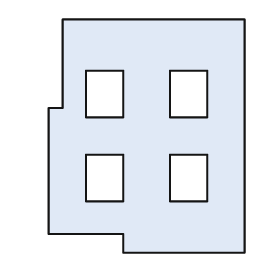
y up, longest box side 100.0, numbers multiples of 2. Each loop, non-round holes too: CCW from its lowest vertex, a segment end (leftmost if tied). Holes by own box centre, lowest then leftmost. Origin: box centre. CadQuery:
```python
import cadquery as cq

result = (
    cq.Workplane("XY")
    .moveTo(-10.0, -50.0)
    .lineTo(42.0, -50.0)
    .lineTo(42.0, 50.0)
    .lineTo(-36.0, 50.0)
    .lineTo(-36.0, 12.0)
    .lineTo(-42.0, 12.0)
    .lineTo(-42.0, -42.0)
    .lineTo(-10.0, -42.0)
    .close()
    .moveTo(-26.0, -28.0)
    .lineTo(-10.0, -28.0)
    .lineTo(-10.0, -8.0)
    .lineTo(-26.0, -8.0)
    .close()
    .moveTo(10.0, -28.0)
    .lineTo(26.0, -28.0)
    .lineTo(26.0, -8.0)
    .lineTo(10.0, -8.0)
    .close()
    .moveTo(-26.0, 8.0)
    .lineTo(-10.0, 8.0)
    .lineTo(-10.0, 28.0)
    .lineTo(-26.0, 28.0)
    .close()
    .moveTo(10.0, 8.0)
    .lineTo(26.0, 8.0)
    .lineTo(26.0, 28.0)
    .lineTo(10.0, 28.0)
    .close()
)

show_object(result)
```